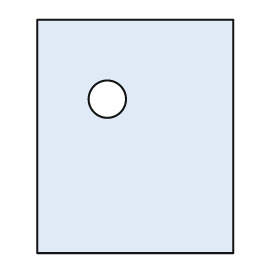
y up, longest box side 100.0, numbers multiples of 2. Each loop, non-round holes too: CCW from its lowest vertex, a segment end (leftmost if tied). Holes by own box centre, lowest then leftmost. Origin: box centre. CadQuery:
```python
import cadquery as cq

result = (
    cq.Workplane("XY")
    .moveTo(-42.0, -50.0)
    .lineTo(42.0, -50.0)
    .lineTo(42.0, 50.0)
    .lineTo(-42.0, 50.0)
    .close()
    .moveTo(-12.0, 16.0)
    .circle(8.0)
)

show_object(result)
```